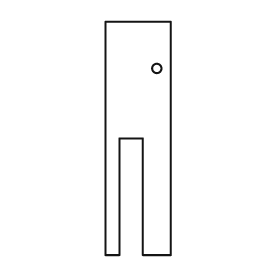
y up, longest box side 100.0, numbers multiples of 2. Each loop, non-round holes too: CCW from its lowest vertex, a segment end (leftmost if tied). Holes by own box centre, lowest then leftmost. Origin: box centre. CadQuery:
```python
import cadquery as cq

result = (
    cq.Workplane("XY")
    .moveTo(-14.0, -50.0)
    .lineTo(-8.0, -50.0)
    .lineTo(-8.0, 0.0)
    .lineTo(2.0, 0.0)
    .lineTo(2.0, -50.0)
    .lineTo(14.0, -50.0)
    .lineTo(14.0, 50.0)
    .lineTo(-14.0, 50.0)
    .close()
    .moveTo(8.0, 30.0)
    .circle(2.0)
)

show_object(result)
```